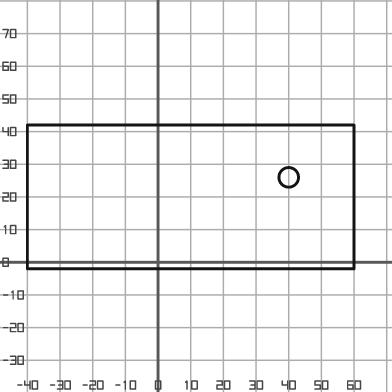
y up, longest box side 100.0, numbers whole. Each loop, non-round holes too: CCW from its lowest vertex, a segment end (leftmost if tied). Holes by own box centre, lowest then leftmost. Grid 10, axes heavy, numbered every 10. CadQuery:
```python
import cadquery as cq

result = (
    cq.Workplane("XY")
    .moveTo(-40.0, -2.0)
    .lineTo(60.0, -2.0)
    .lineTo(60.0, 42.0)
    .lineTo(-40.0, 42.0)
    .close()
    .moveTo(40.0, 26.0)
    .circle(3.0)
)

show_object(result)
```